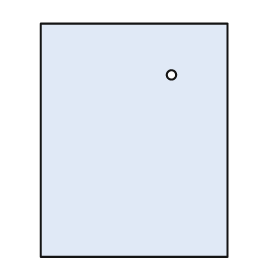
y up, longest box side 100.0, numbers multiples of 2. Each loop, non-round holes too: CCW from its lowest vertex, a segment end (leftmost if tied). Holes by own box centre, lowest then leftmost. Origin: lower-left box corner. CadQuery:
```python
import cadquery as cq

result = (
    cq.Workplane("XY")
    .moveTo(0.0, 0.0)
    .lineTo(80.0, 0.0)
    .lineTo(80.0, 100.0)
    .lineTo(0.0, 100.0)
    .close()
    .moveTo(56.0, 78.0)
    .circle(2.0)
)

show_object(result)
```